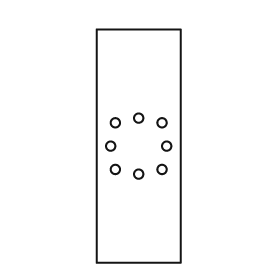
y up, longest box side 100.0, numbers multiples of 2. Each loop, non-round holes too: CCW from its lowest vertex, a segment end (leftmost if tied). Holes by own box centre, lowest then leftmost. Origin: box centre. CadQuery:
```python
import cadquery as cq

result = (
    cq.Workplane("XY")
    .moveTo(-18.0, -50.0)
    .lineTo(18.0, -50.0)
    .lineTo(18.0, 50.0)
    .lineTo(-18.0, 50.0)
    .close()
    .moveTo(0.0, -12.0)
    .circle(2.0)
    .moveTo(-10.0, -10.0)
    .circle(2.0)
    .moveTo(10.0, -10.0)
    .circle(2.0)
    .moveTo(-12.0, 0.0)
    .circle(2.0)
    .moveTo(12.0, 0.0)
    .circle(2.0)
    .moveTo(-10.0, 10.0)
    .circle(2.0)
    .moveTo(10.0, 10.0)
    .circle(2.0)
    .moveTo(0.0, 12.0)
    .circle(2.0)
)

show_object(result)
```